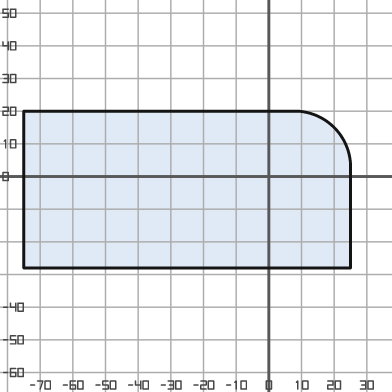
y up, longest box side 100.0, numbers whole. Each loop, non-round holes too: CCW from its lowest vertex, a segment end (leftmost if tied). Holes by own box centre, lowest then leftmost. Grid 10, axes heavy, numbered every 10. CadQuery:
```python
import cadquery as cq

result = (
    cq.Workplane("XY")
    .moveTo(-75.0, -28.0)
    .lineTo(25.0, -28.0)
    .lineTo(25.0, 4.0)
    .threePointArc((20.0, 15.0), (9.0, 20.0))
    .lineTo(-75.0, 20.0)
    .close()
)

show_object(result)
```